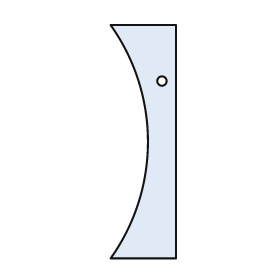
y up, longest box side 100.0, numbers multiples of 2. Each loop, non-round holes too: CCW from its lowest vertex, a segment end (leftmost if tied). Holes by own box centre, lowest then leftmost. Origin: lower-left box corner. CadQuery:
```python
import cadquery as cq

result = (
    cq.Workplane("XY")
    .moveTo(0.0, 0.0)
    .lineTo(28.0, 0.0)
    .lineTo(28.0, 100.0)
    .lineTo(0.0, 100.0)
    .threePointArc((16.0, 50.0), (0.0, 0.0))
    .close()
    .moveTo(22.0, 76.0)
    .circle(2.0)
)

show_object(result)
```